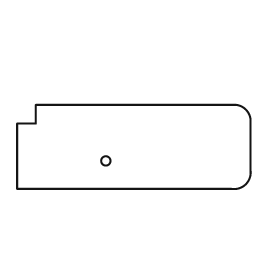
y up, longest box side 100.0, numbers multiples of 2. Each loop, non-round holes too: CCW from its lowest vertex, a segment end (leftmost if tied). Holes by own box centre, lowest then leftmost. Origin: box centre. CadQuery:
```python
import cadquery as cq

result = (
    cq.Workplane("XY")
    .moveTo(-50.0, -18.0)
    .lineTo(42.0, -18.0)
    .threePointArc((48.0, -16.0), (50.0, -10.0))
    .lineTo(50.0, 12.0)
    .threePointArc((48.0, 16.0), (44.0, 18.0))
    .lineTo(-42.0, 18.0)
    .lineTo(-42.0, 10.0)
    .lineTo(-50.0, 10.0)
    .close()
    .moveTo(-12.0, -6.0)
    .circle(2.0)
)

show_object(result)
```